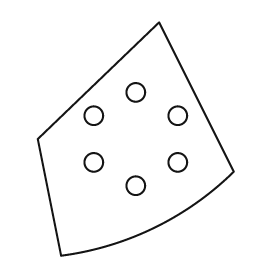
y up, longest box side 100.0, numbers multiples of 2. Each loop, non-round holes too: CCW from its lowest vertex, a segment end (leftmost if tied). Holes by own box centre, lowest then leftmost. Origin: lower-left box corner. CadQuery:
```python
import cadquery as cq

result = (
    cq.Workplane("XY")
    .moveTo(10.0, 0.0)
    .threePointArc((50.0, 12.0), (84.0, 36.0))
    .lineTo(52.0, 100.0)
    .lineTo(0.0, 50.0)
    .close()
    .moveTo(42.0, 30.0)
    .circle(4.0)
    .moveTo(24.0, 40.0)
    .circle(4.0)
    .moveTo(60.0, 40.0)
    .circle(4.0)
    .moveTo(24.0, 60.0)
    .circle(4.0)
    .moveTo(60.0, 60.0)
    .circle(4.0)
    .moveTo(42.0, 70.0)
    .circle(4.0)
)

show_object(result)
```